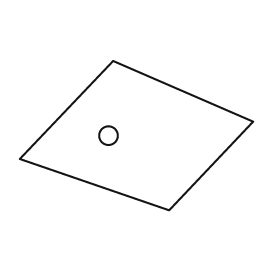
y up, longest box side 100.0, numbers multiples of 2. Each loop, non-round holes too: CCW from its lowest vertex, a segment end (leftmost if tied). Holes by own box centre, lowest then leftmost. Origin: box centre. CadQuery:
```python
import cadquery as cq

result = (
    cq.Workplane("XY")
    .moveTo(14.0, -32.0)
    .lineTo(50.0, 6.0)
    .lineTo(-10.0, 32.0)
    .lineTo(-50.0, -10.0)
    .close()
    .moveTo(-12.0, 0.0)
    .circle(4.0)
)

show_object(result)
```